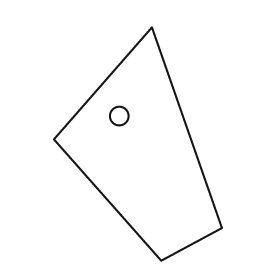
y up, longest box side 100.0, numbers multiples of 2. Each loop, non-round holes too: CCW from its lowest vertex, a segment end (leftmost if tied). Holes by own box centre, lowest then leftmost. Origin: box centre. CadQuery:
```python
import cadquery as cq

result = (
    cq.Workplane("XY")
    .moveTo(10.0, -50.0)
    .lineTo(36.0, -36.0)
    .lineTo(6.0, 50.0)
    .lineTo(-36.0, 2.0)
    .close()
    .moveTo(-8.0, 12.0)
    .circle(4.0)
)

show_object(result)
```